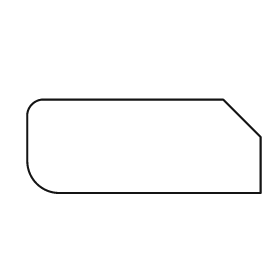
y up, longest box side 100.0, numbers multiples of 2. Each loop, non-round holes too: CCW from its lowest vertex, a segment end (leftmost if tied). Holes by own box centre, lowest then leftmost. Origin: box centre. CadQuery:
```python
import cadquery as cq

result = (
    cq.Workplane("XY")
    .moveTo(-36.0, -20.0)
    .lineTo(50.0, -20.0)
    .lineTo(50.0, 4.0)
    .lineTo(34.0, 20.0)
    .lineTo(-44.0, 20.0)
    .threePointArc((-48.0, 18.0), (-50.0, 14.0))
    .lineTo(-50.0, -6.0)
    .threePointArc((-46.0, -16.0), (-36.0, -20.0))
    .close()
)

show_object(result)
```